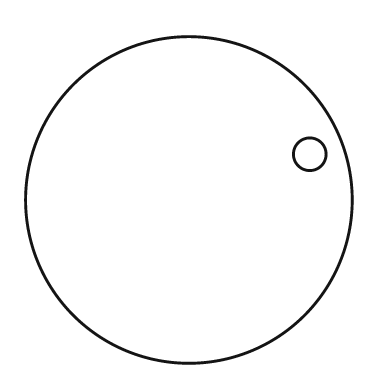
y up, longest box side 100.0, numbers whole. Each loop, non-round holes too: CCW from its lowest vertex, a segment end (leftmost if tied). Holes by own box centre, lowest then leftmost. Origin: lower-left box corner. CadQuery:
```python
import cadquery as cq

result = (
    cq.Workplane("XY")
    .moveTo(50.0, 50.0)
    .circle(50.0)
    .moveTo(87.0, 64.0)
    .circle(5.0)
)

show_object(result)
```